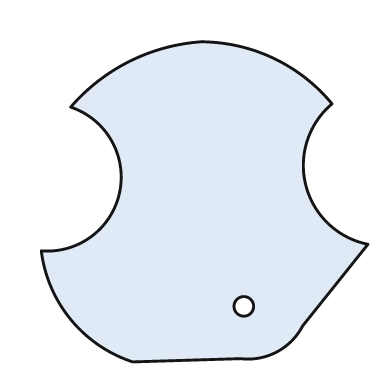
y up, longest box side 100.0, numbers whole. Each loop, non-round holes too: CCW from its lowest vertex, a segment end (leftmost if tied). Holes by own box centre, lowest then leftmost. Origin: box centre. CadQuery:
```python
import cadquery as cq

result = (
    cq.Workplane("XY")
    .moveTo(-22.0, -49.0)
    .lineTo(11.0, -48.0)
    .threePointArc((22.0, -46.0), (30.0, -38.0))
    .lineTo(50.0, -13.0)
    .threePointArc((31.0, 5.0), (39.0, 30.0))
    .threePointArc((21.0, 44.0), (-1.0, 49.0))
    .threePointArc((-23.0, 43.0), (-41.0, 29.0))
    .threePointArc((-26.0, 3.0), (-50.0, -15.0))
    .threePointArc((-41.0, -36.0), (-22.0, -49.0))
    .close()
    .moveTo(12.0, -32.0)
    .circle(3.0)
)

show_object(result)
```